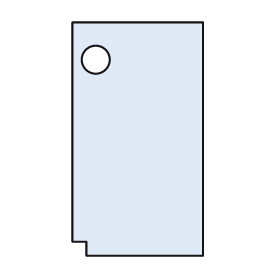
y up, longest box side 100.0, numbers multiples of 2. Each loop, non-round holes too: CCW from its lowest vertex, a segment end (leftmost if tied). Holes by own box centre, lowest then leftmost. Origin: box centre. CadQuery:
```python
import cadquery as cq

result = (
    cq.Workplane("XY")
    .moveTo(-22.0, -50.0)
    .lineTo(28.0, -50.0)
    .lineTo(28.0, 50.0)
    .lineTo(-28.0, 50.0)
    .lineTo(-28.0, -44.0)
    .lineTo(-22.0, -44.0)
    .close()
    .moveTo(-18.0, 34.0)
    .circle(6.0)
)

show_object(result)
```